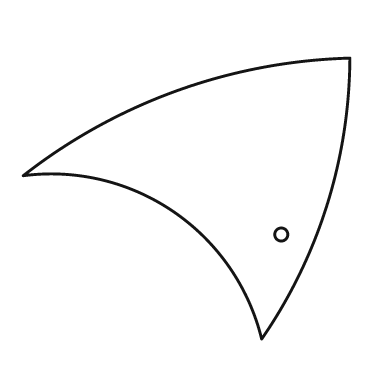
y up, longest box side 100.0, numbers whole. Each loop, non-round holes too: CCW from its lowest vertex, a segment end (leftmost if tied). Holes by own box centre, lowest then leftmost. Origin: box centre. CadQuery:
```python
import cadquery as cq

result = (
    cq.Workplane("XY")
    .moveTo(23.0, -43.0)
    .threePointArc((43.0, -2.0), (50.0, 43.0))
    .threePointArc((-3.0, 33.0), (-50.0, 7.0))
    .threePointArc((-4.0, -4.0), (23.0, -43.0))
    .close()
    .moveTo(29.0, -11.0)
    .circle(2.0)
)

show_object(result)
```